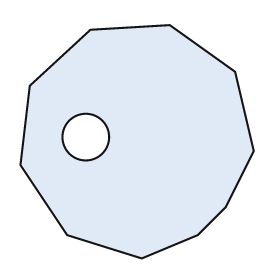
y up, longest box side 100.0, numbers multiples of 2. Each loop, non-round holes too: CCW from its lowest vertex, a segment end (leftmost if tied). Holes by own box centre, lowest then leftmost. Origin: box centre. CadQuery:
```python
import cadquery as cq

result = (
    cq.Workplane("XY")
    .moveTo(2.0, -50.0)
    .lineTo(26.0, -40.0)
    .lineTo(38.0, -28.0)
    .lineTo(50.0, -4.0)
    .lineTo(42.0, 30.0)
    .lineTo(14.0, 50.0)
    .lineTo(-20.0, 48.0)
    .lineTo(-46.0, 24.0)
    .lineTo(-50.0, -10.0)
    .lineTo(-30.0, -40.0)
    .close()
    .moveTo(-22.0, 2.0)
    .circle(10.0)
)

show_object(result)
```